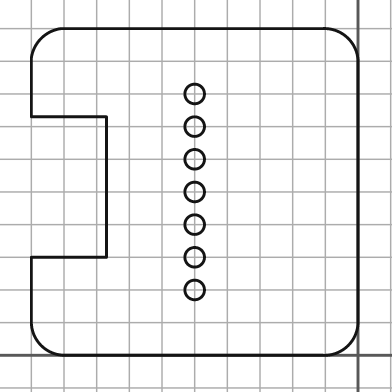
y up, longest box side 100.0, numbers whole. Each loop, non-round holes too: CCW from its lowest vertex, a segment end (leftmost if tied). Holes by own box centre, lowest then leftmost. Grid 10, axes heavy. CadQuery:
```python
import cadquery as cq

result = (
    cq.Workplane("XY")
    .moveTo(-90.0, 0.0)
    .lineTo(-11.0, 0.0)
    .threePointArc((-3.0, 3.0), (0.0, 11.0))
    .lineTo(0.0, 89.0)
    .threePointArc((-3.0, 97.0), (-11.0, 100.0))
    .lineTo(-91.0, 100.0)
    .threePointArc((-97.0, 97.0), (-100.0, 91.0))
    .lineTo(-100.0, 73.0)
    .lineTo(-77.0, 73.0)
    .lineTo(-77.0, 30.0)
    .lineTo(-100.0, 30.0)
    .lineTo(-100.0, 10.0)
    .threePointArc((-97.0, 3.0), (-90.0, 0.0))
    .close()
    .moveTo(-50.0, 20.0)
    .circle(3.0)
    .moveTo(-50.0, 30.0)
    .circle(3.0)
    .moveTo(-50.0, 40.0)
    .circle(3.0)
    .moveTo(-50.0, 50.0)
    .circle(3.0)
    .moveTo(-50.0, 60.0)
    .circle(3.0)
    .moveTo(-50.0, 70.0)
    .circle(3.0)
    .moveTo(-50.0, 80.0)
    .circle(3.0)
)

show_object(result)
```